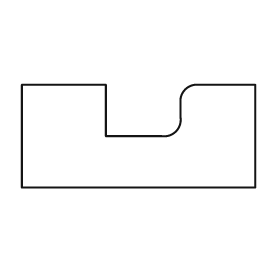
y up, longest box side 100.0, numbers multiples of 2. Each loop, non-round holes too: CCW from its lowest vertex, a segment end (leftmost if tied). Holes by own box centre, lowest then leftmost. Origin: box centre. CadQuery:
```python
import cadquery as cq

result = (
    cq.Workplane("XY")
    .moveTo(-50.0, -22.0)
    .lineTo(50.0, -22.0)
    .lineTo(50.0, 22.0)
    .lineTo(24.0, 22.0)
    .threePointArc((20.0, 20.0), (18.0, 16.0))
    .lineTo(18.0, 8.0)
    .threePointArc((16.0, 2.0), (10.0, 0.0))
    .lineTo(-14.0, 0.0)
    .lineTo(-14.0, 22.0)
    .lineTo(-50.0, 22.0)
    .close()
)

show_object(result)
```